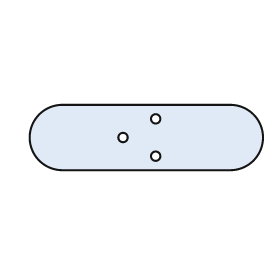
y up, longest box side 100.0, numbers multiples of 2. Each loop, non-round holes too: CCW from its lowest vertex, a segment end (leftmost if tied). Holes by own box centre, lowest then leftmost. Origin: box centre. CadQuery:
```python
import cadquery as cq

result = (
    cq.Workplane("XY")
    .moveTo(-36.0, -14.0)
    .lineTo(36.0, -14.0)
    .threePointArc((50.0, 0.0), (36.0, 14.0))
    .lineTo(-36.0, 14.0)
    .threePointArc((-50.0, 0.0), (-36.0, -14.0))
    .close()
    .moveTo(4.0, -8.0)
    .circle(2.0)
    .moveTo(-10.0, 0.0)
    .circle(2.0)
    .moveTo(4.0, 8.0)
    .circle(2.0)
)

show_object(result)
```